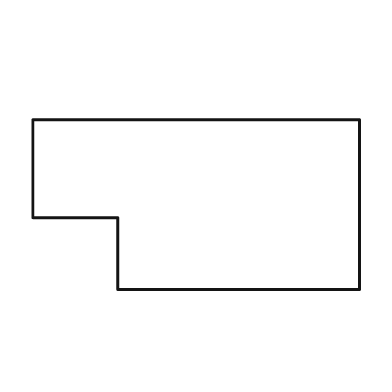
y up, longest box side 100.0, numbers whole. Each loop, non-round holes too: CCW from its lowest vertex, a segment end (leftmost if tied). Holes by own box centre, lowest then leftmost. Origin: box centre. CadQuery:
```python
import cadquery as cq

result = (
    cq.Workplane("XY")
    .moveTo(-24.0, -26.0)
    .lineTo(50.0, -26.0)
    .lineTo(50.0, 26.0)
    .lineTo(-50.0, 26.0)
    .lineTo(-50.0, -4.0)
    .lineTo(-24.0, -4.0)
    .close()
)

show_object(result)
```